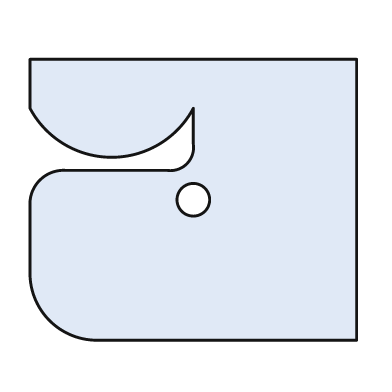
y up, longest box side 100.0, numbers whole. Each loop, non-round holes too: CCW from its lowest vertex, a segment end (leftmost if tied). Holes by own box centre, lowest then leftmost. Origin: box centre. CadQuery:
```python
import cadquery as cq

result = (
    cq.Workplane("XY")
    .moveTo(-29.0, -43.0)
    .lineTo(50.0, -43.0)
    .lineTo(50.0, 43.0)
    .lineTo(-50.0, 43.0)
    .lineTo(-50.0, 28.0)
    .threePointArc((-25.0, 13.0), (0.0, 28.0))
    .lineTo(0.0, 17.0)
    .threePointArc((-2.0, 11.0), (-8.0, 9.0))
    .lineTo(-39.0, 9.0)
    .threePointArc((-47.0, 6.0), (-50.0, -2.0))
    .lineTo(-50.0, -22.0)
    .threePointArc((-44.0, -37.0), (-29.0, -43.0))
    .close()
    .moveTo(0.0, 0.0)
    .circle(5.0)
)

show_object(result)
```